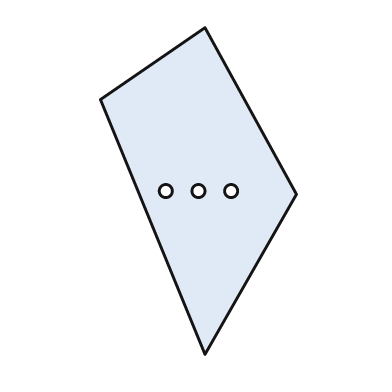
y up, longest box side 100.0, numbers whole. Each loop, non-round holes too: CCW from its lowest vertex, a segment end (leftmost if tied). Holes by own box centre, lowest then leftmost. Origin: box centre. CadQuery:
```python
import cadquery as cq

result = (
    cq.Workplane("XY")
    .moveTo(2.0, -50.0)
    .lineTo(30.0, -1.0)
    .lineTo(2.0, 50.0)
    .lineTo(-30.0, 28.0)
    .close()
    .moveTo(-10.0, 0.0)
    .circle(2.0)
    .moveTo(0.0, 0.0)
    .circle(2.0)
    .moveTo(10.0, 0.0)
    .circle(2.0)
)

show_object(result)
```